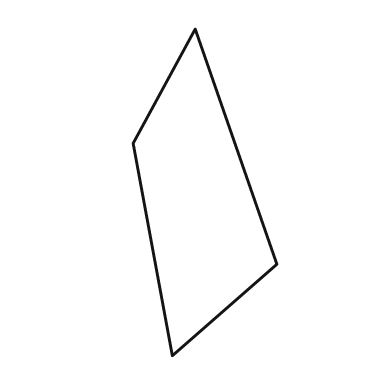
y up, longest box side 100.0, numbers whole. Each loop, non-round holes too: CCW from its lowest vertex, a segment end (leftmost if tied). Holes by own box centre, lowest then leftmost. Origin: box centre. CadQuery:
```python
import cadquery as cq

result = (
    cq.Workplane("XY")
    .moveTo(-10.0, -50.0)
    .lineTo(22.0, -22.0)
    .lineTo(-3.0, 50.0)
    .lineTo(-22.0, 15.0)
    .close()
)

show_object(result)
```